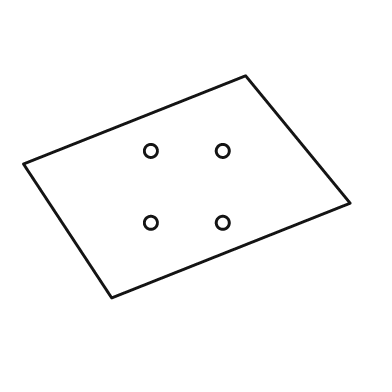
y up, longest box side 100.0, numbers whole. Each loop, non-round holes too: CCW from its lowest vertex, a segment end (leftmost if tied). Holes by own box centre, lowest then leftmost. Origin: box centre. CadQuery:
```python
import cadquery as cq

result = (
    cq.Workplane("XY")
    .moveTo(-23.0, -34.0)
    .lineTo(50.0, -5.0)
    .lineTo(18.0, 34.0)
    .lineTo(-50.0, 7.0)
    .close()
    .moveTo(-11.0, -11.0)
    .circle(2.0)
    .moveTo(11.0, -11.0)
    .circle(2.0)
    .moveTo(-11.0, 11.0)
    .circle(2.0)
    .moveTo(11.0, 11.0)
    .circle(2.0)
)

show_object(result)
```